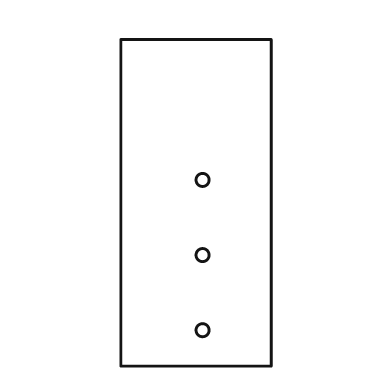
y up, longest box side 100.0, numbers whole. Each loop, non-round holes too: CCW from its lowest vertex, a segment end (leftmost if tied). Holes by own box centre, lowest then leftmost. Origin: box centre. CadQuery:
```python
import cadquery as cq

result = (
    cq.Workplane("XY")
    .moveTo(-23.0, -50.0)
    .lineTo(23.0, -50.0)
    .lineTo(23.0, 50.0)
    .lineTo(-23.0, 50.0)
    .close()
    .moveTo(2.0, -39.0)
    .circle(2.0)
    .moveTo(2.0, -16.0)
    .circle(2.0)
    .moveTo(2.0, 7.0)
    .circle(2.0)
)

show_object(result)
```